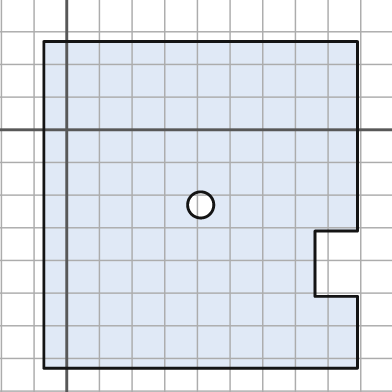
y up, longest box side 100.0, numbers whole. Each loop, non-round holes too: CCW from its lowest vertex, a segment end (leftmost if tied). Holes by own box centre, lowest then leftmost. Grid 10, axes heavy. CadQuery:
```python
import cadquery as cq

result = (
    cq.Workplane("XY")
    .moveTo(-7.0, -73.0)
    .lineTo(89.0, -73.0)
    .lineTo(89.0, -51.0)
    .lineTo(76.0, -51.0)
    .lineTo(76.0, -31.0)
    .lineTo(89.0, -31.0)
    .lineTo(89.0, 27.0)
    .lineTo(-7.0, 27.0)
    .close()
    .moveTo(41.0, -23.0)
    .circle(4.0)
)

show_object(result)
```